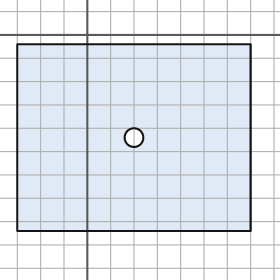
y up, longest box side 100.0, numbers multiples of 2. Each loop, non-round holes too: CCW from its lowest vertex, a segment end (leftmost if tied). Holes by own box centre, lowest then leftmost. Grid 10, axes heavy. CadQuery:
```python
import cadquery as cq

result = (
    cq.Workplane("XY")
    .moveTo(-30.0, -84.0)
    .lineTo(70.0, -84.0)
    .lineTo(70.0, -4.0)
    .lineTo(-30.0, -4.0)
    .close()
    .moveTo(20.0, -44.0)
    .circle(4.0)
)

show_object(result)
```